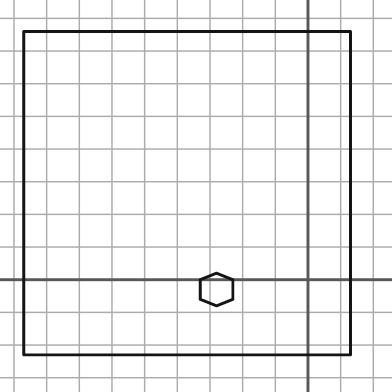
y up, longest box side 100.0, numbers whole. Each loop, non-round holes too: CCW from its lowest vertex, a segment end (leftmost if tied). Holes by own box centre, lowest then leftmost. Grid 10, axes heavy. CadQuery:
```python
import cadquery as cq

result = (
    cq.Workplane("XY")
    .moveTo(-87.0, -23.0)
    .lineTo(13.0, -23.0)
    .lineTo(13.0, 76.0)
    .lineTo(-87.0, 76.0)
    .close()
    .moveTo(-28.0, -8.0)
    .lineTo(-23.0, -6.0)
    .lineTo(-23.0, 0.0)
    .lineTo(-28.0, 2.0)
    .lineTo(-33.0, 0.0)
    .lineTo(-33.0, -6.0)
    .close()
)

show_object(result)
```